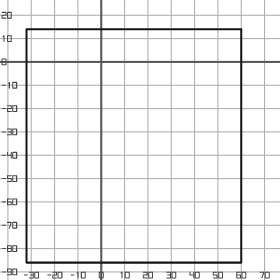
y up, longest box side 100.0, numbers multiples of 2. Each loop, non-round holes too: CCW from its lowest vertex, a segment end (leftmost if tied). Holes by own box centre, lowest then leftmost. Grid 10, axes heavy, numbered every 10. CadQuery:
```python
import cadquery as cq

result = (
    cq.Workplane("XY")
    .moveTo(-32.0, -86.0)
    .lineTo(60.0, -86.0)
    .lineTo(60.0, 14.0)
    .lineTo(-32.0, 14.0)
    .close()
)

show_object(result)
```